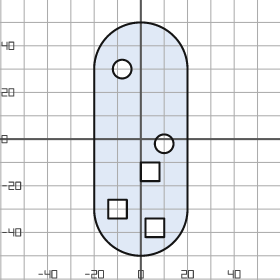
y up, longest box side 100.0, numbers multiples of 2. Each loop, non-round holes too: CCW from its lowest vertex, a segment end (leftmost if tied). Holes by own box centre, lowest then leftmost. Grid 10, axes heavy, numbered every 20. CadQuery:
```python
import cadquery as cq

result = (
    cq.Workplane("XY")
    .moveTo(-20.0, -30.0)
    .threePointArc((0.0, -50.0), (20.0, -30.0))
    .lineTo(20.0, 30.0)
    .threePointArc((0.0, 50.0), (-20.0, 30.0))
    .close()
    .moveTo(2.0, -42.0)
    .lineTo(10.0, -42.0)
    .lineTo(10.0, -34.0)
    .lineTo(2.0, -34.0)
    .close()
    .moveTo(-14.0, -34.0)
    .lineTo(-6.0, -34.0)
    .lineTo(-6.0, -26.0)
    .lineTo(-14.0, -26.0)
    .close()
    .moveTo(0.0, -18.0)
    .lineTo(8.0, -18.0)
    .lineTo(8.0, -10.0)
    .lineTo(0.0, -10.0)
    .close()
    .moveTo(10.0, -2.0)
    .circle(4.0)
    .moveTo(-8.0, 30.0)
    .circle(4.0)
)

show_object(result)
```